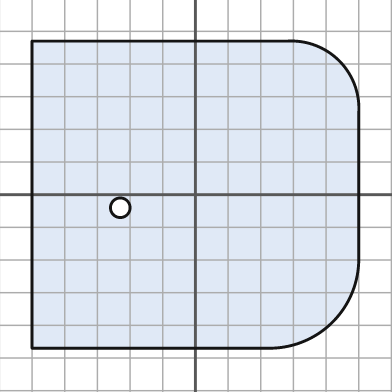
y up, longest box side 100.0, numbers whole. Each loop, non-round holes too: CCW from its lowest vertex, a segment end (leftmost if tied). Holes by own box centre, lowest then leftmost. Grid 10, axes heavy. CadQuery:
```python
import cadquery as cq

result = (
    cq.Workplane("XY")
    .moveTo(-50.0, -47.0)
    .lineTo(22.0, -47.0)
    .threePointArc((42.0, -39.0), (50.0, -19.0))
    .lineTo(50.0, 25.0)
    .threePointArc((44.0, 41.0), (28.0, 47.0))
    .lineTo(-50.0, 47.0)
    .close()
    .moveTo(-23.0, -4.0)
    .circle(3.0)
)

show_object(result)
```